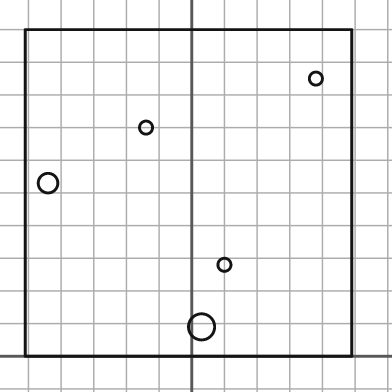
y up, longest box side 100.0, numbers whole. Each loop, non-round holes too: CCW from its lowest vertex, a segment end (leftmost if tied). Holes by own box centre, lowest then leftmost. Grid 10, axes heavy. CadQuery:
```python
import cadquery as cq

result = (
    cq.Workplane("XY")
    .moveTo(-51.0, 0.0)
    .lineTo(49.0, 0.0)
    .lineTo(49.0, 100.0)
    .lineTo(-51.0, 100.0)
    .close()
    .moveTo(3.0, 9.0)
    .circle(4.0)
    .moveTo(10.0, 28.0)
    .circle(2.0)
    .moveTo(-44.0, 53.0)
    .circle(3.0)
    .moveTo(-14.0, 70.0)
    .circle(2.0)
    .moveTo(38.0, 85.0)
    .circle(2.0)
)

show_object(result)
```